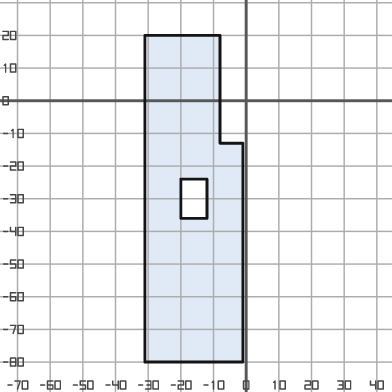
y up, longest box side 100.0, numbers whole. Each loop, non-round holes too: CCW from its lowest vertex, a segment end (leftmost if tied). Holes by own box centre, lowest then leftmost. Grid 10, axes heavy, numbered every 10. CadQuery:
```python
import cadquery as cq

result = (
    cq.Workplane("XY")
    .moveTo(-31.0, -80.0)
    .lineTo(-1.0, -80.0)
    .lineTo(-1.0, -13.0)
    .lineTo(-8.0, -13.0)
    .lineTo(-8.0, 20.0)
    .lineTo(-31.0, 20.0)
    .close()
    .moveTo(-20.0, -36.0)
    .lineTo(-12.0, -36.0)
    .lineTo(-12.0, -24.0)
    .lineTo(-20.0, -24.0)
    .close()
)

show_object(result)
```